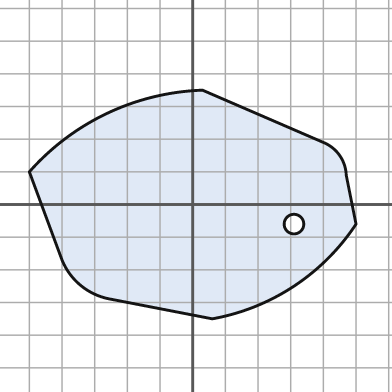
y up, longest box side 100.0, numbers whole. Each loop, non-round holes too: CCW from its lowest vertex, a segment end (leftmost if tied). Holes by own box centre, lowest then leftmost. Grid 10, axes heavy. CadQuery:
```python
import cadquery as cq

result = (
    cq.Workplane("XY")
    .moveTo(6.0, -35.0)
    .threePointArc((31.0, -25.0), (50.0, -6.0))
    .lineTo(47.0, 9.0)
    .threePointArc((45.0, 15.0), (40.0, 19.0))
    .lineTo(3.0, 35.0)
    .threePointArc((-26.0, 28.0), (-50.0, 10.0))
    .lineTo(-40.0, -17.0)
    .threePointArc((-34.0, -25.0), (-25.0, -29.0))
    .close()
    .moveTo(31.0, -6.0)
    .circle(3.0)
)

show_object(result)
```